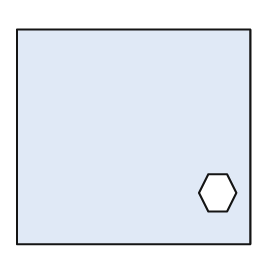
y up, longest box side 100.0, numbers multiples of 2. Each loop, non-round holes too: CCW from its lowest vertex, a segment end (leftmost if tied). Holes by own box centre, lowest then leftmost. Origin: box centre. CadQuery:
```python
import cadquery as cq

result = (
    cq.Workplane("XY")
    .moveTo(-50.0, -46.0)
    .lineTo(50.0, -46.0)
    .lineTo(50.0, 46.0)
    .lineTo(-50.0, 46.0)
    .close()
    .moveTo(32.0, -32.0)
    .lineTo(40.0, -32.0)
    .lineTo(44.0, -24.0)
    .lineTo(40.0, -16.0)
    .lineTo(32.0, -16.0)
    .lineTo(28.0, -24.0)
    .close()
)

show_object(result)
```